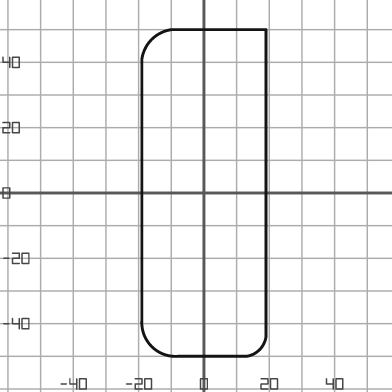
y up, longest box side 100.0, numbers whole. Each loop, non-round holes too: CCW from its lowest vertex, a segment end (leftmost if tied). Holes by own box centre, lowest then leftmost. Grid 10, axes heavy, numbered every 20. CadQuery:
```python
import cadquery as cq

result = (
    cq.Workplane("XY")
    .moveTo(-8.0, -50.0)
    .lineTo(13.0, -50.0)
    .threePointArc((17.0, -48.0), (19.0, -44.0))
    .lineTo(19.0, 50.0)
    .lineTo(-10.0, 50.0)
    .threePointArc((-16.0, 47.0), (-19.0, 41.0))
    .lineTo(-19.0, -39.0)
    .threePointArc((-16.0, -47.0), (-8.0, -50.0))
    .close()
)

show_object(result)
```